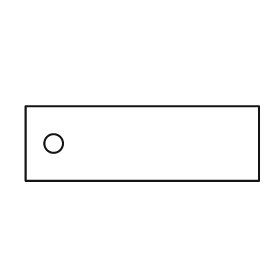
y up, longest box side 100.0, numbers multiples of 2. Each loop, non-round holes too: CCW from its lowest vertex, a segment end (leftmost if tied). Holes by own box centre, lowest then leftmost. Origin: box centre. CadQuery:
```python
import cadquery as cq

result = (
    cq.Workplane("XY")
    .moveTo(-50.0, -16.0)
    .lineTo(50.0, -16.0)
    .lineTo(50.0, 16.0)
    .lineTo(-50.0, 16.0)
    .close()
    .moveTo(-38.0, 0.0)
    .circle(4.0)
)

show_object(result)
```